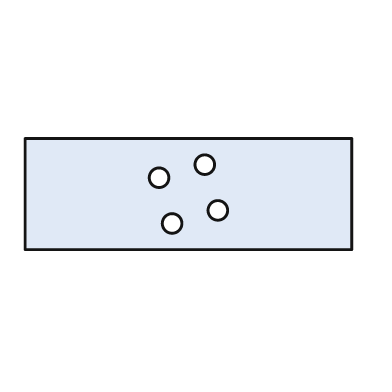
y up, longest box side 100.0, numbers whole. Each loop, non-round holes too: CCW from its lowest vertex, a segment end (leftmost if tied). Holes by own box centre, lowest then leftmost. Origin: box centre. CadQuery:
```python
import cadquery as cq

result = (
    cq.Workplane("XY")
    .moveTo(-50.0, -17.0)
    .lineTo(50.0, -17.0)
    .lineTo(50.0, 17.0)
    .lineTo(-50.0, 17.0)
    .close()
    .moveTo(-5.0, -9.0)
    .circle(3.0)
    .moveTo(9.0, -5.0)
    .circle(3.0)
    .moveTo(-9.0, 5.0)
    .circle(3.0)
    .moveTo(5.0, 9.0)
    .circle(3.0)
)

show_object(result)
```